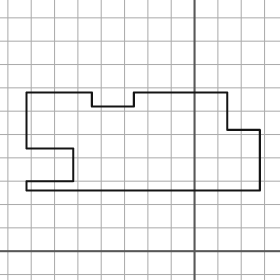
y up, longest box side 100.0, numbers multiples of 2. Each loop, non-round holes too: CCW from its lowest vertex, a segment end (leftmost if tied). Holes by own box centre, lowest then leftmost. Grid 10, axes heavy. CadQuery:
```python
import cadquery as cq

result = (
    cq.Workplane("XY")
    .moveTo(-72.0, 26.0)
    .lineTo(28.0, 26.0)
    .lineTo(28.0, 52.0)
    .lineTo(14.0, 52.0)
    .lineTo(14.0, 68.0)
    .lineTo(-26.0, 68.0)
    .lineTo(-26.0, 62.0)
    .lineTo(-44.0, 62.0)
    .lineTo(-44.0, 68.0)
    .lineTo(-72.0, 68.0)
    .lineTo(-72.0, 44.0)
    .lineTo(-52.0, 44.0)
    .lineTo(-52.0, 30.0)
    .lineTo(-72.0, 30.0)
    .close()
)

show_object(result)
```